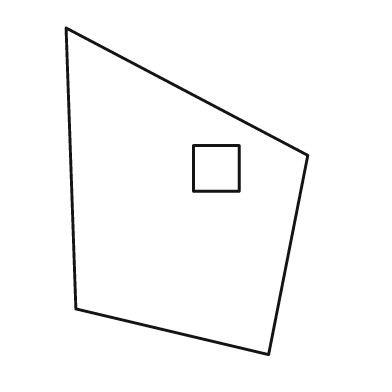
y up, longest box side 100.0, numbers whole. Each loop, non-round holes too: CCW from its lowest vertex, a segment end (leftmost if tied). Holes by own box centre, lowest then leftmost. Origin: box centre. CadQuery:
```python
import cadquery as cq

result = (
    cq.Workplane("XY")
    .moveTo(25.0, -50.0)
    .lineTo(37.0, 11.0)
    .lineTo(-37.0, 50.0)
    .lineTo(-34.0, -36.0)
    .close()
    .moveTo(2.0, 0.0)
    .lineTo(16.0, 0.0)
    .lineTo(16.0, 14.0)
    .lineTo(2.0, 14.0)
    .close()
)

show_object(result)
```